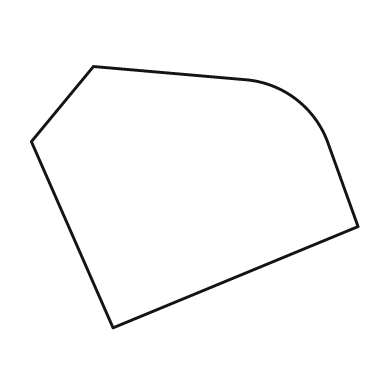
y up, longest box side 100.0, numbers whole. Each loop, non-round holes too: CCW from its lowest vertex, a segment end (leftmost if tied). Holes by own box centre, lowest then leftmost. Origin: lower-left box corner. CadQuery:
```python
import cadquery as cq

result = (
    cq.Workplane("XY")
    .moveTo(25.0, 0.0)
    .lineTo(100.0, 31.0)
    .lineTo(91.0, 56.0)
    .threePointArc((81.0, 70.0), (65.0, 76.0))
    .lineTo(19.0, 80.0)
    .lineTo(0.0, 57.0)
    .close()
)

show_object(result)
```